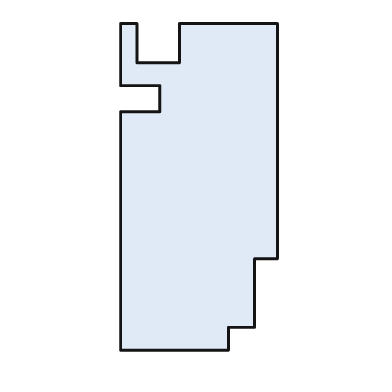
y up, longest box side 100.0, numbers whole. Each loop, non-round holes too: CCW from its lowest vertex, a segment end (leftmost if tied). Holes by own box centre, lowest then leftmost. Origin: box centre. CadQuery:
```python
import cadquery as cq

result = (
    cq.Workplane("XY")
    .moveTo(-24.0, -50.0)
    .lineTo(9.0, -50.0)
    .lineTo(9.0, -43.0)
    .lineTo(17.0, -43.0)
    .lineTo(17.0, -22.0)
    .lineTo(24.0, -22.0)
    .lineTo(24.0, 50.0)
    .lineTo(-6.0, 50.0)
    .lineTo(-6.0, 38.0)
    .lineTo(-19.0, 38.0)
    .lineTo(-19.0, 50.0)
    .lineTo(-24.0, 50.0)
    .lineTo(-24.0, 31.0)
    .lineTo(-12.0, 31.0)
    .lineTo(-12.0, 23.0)
    .lineTo(-24.0, 23.0)
    .close()
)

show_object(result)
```